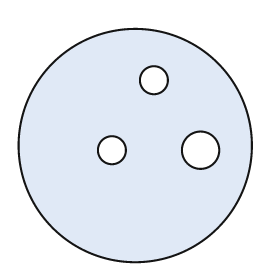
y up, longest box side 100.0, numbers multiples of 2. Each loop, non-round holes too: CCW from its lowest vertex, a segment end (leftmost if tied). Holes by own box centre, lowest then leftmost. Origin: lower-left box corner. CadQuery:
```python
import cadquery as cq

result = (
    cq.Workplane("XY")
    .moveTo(50.0, 50.0)
    .circle(50.0)
    .moveTo(40.0, 48.0)
    .circle(6.0)
    .moveTo(78.0, 48.0)
    .circle(8.0)
    .moveTo(58.0, 78.0)
    .circle(6.0)
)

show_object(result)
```